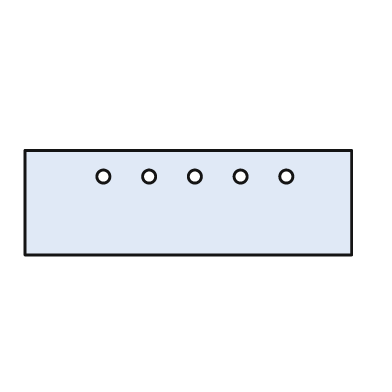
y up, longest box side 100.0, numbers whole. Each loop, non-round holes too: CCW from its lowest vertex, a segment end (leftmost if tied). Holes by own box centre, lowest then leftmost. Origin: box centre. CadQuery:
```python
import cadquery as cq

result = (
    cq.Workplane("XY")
    .moveTo(-50.0, -16.0)
    .lineTo(50.0, -16.0)
    .lineTo(50.0, 16.0)
    .lineTo(-50.0, 16.0)
    .close()
    .moveTo(-26.0, 8.0)
    .circle(2.0)
    .moveTo(-12.0, 8.0)
    .circle(2.0)
    .moveTo(2.0, 8.0)
    .circle(2.0)
    .moveTo(16.0, 8.0)
    .circle(2.0)
    .moveTo(30.0, 8.0)
    .circle(2.0)
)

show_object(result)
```